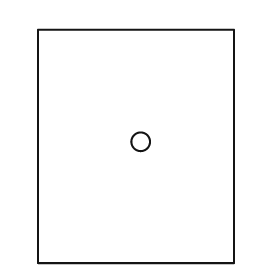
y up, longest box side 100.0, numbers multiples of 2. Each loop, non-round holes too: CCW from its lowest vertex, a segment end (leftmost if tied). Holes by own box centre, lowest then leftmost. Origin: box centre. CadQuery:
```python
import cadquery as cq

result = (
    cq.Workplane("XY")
    .moveTo(-42.0, -50.0)
    .lineTo(42.0, -50.0)
    .lineTo(42.0, 50.0)
    .lineTo(-42.0, 50.0)
    .close()
    .moveTo(2.0, 2.0)
    .circle(4.0)
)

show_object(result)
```